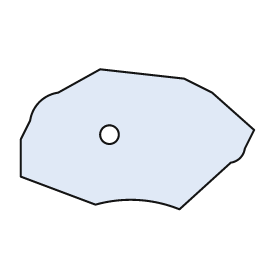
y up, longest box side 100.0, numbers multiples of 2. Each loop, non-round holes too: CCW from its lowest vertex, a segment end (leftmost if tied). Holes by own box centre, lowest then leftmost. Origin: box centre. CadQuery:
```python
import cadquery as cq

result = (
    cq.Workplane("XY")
    .moveTo(18.0, -30.0)
    .lineTo(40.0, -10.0)
    .threePointArc((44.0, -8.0), (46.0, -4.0))
    .lineTo(50.0, 4.0)
    .lineTo(32.0, 20.0)
    .lineTo(20.0, 26.0)
    .lineTo(-16.0, 30.0)
    .lineTo(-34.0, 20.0)
    .threePointArc((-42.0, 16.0), (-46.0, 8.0))
    .lineTo(-50.0, 0.0)
    .lineTo(-50.0, -16.0)
    .lineTo(-18.0, -28.0)
    .threePointArc((0.0, -26.0), (18.0, -30.0))
    .close()
    .moveTo(-12.0, 2.0)
    .circle(4.0)
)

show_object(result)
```